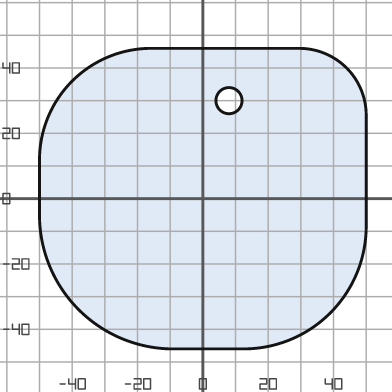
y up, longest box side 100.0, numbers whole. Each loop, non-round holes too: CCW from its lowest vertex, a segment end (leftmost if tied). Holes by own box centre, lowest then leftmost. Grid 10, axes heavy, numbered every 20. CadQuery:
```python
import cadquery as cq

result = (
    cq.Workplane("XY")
    .moveTo(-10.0, -46.0)
    .lineTo(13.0, -46.0)
    .threePointArc((39.0, -35.0), (50.0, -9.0))
    .lineTo(50.0, 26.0)
    .threePointArc((44.0, 40.0), (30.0, 46.0))
    .lineTo(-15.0, 46.0)
    .threePointArc((-40.0, 36.0), (-50.0, 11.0))
    .lineTo(-50.0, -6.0)
    .threePointArc((-38.0, -34.0), (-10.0, -46.0))
    .close()
    .moveTo(8.0, 30.0)
    .circle(4.0)
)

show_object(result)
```